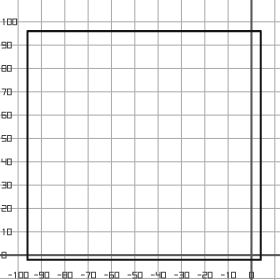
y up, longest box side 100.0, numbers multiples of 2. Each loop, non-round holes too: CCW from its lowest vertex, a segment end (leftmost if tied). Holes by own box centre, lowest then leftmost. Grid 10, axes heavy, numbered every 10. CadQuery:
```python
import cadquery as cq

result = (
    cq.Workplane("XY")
    .moveTo(-96.0, -2.0)
    .lineTo(4.0, -2.0)
    .lineTo(4.0, 96.0)
    .lineTo(-96.0, 96.0)
    .close()
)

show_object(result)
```